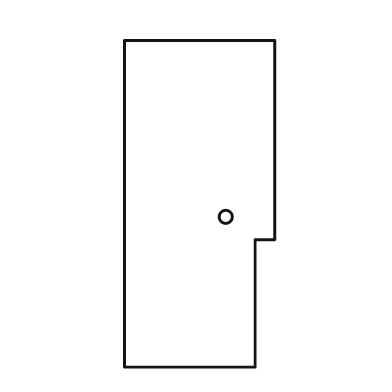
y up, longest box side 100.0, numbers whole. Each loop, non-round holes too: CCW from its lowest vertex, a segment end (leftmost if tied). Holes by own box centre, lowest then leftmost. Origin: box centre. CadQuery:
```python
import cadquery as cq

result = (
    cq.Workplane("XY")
    .moveTo(-23.0, -50.0)
    .lineTo(17.0, -50.0)
    .lineTo(17.0, -11.0)
    .lineTo(23.0, -11.0)
    .lineTo(23.0, 50.0)
    .lineTo(-23.0, 50.0)
    .close()
    .moveTo(8.0, -4.0)
    .circle(2.0)
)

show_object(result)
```